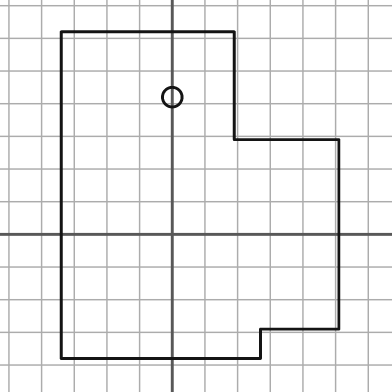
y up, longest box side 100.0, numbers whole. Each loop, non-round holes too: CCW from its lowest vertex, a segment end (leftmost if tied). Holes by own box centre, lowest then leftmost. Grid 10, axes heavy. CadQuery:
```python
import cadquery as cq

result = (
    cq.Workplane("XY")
    .moveTo(-34.0, -38.0)
    .lineTo(27.0, -38.0)
    .lineTo(27.0, -29.0)
    .lineTo(51.0, -29.0)
    .lineTo(51.0, 29.0)
    .lineTo(19.0, 29.0)
    .lineTo(19.0, 62.0)
    .lineTo(-34.0, 62.0)
    .close()
    .moveTo(0.0, 42.0)
    .circle(3.0)
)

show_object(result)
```